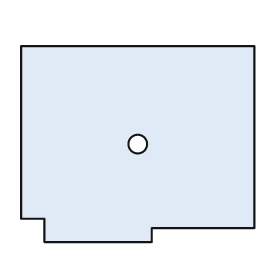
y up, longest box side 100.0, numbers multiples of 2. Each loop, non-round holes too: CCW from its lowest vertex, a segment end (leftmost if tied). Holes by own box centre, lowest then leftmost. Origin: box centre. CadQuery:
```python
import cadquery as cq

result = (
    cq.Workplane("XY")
    .moveTo(-40.0, -42.0)
    .lineTo(6.0, -42.0)
    .lineTo(6.0, -36.0)
    .lineTo(50.0, -36.0)
    .lineTo(50.0, 42.0)
    .lineTo(-50.0, 42.0)
    .lineTo(-50.0, -32.0)
    .lineTo(-40.0, -32.0)
    .close()
    .moveTo(0.0, 0.0)
    .circle(4.0)
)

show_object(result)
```